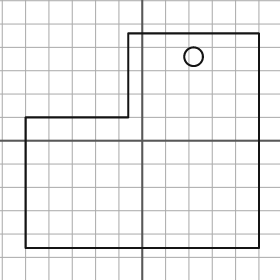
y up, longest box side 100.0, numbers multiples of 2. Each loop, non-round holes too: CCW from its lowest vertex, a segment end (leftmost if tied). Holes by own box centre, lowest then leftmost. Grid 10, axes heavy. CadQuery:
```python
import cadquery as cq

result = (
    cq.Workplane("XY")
    .moveTo(-50.0, -46.0)
    .lineTo(50.0, -46.0)
    .lineTo(50.0, 46.0)
    .lineTo(-6.0, 46.0)
    .lineTo(-6.0, 10.0)
    .lineTo(-50.0, 10.0)
    .close()
    .moveTo(22.0, 36.0)
    .circle(4.0)
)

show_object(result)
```